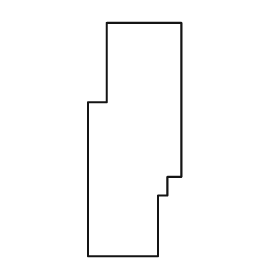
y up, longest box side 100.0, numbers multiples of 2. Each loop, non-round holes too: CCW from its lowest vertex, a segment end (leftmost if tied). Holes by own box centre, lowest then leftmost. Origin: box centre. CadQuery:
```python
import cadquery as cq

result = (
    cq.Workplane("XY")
    .moveTo(-20.0, -50.0)
    .lineTo(10.0, -50.0)
    .lineTo(10.0, -24.0)
    .lineTo(14.0, -24.0)
    .lineTo(14.0, -16.0)
    .lineTo(20.0, -16.0)
    .lineTo(20.0, 50.0)
    .lineTo(-12.0, 50.0)
    .lineTo(-12.0, 16.0)
    .lineTo(-20.0, 16.0)
    .close()
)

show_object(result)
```